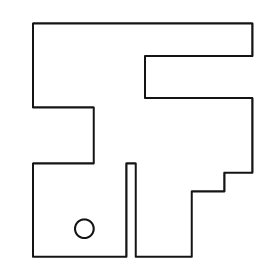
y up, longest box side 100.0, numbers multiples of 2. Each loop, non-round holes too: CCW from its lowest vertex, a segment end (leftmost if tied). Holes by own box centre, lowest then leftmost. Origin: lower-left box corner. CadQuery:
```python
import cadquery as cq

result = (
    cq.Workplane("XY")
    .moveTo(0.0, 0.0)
    .lineTo(40.0, 0.0)
    .lineTo(40.0, 40.0)
    .lineTo(44.0, 40.0)
    .lineTo(44.0, 0.0)
    .lineTo(68.0, 0.0)
    .lineTo(68.0, 28.0)
    .lineTo(82.0, 28.0)
    .lineTo(82.0, 36.0)
    .lineTo(94.0, 36.0)
    .lineTo(94.0, 68.0)
    .lineTo(48.0, 68.0)
    .lineTo(48.0, 86.0)
    .lineTo(94.0, 86.0)
    .lineTo(94.0, 100.0)
    .lineTo(0.0, 100.0)
    .lineTo(0.0, 64.0)
    .lineTo(26.0, 64.0)
    .lineTo(26.0, 40.0)
    .lineTo(0.0, 40.0)
    .close()
    .moveTo(22.0, 12.0)
    .circle(4.0)
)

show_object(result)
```